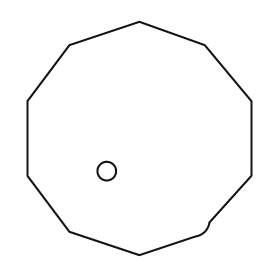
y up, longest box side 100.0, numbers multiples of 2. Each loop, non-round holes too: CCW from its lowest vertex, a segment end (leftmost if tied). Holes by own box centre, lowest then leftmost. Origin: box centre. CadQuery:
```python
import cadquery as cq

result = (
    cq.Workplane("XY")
    .moveTo(0.0, -50.0)
    .lineTo(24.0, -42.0)
    .threePointArc((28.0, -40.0), (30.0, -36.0))
    .lineTo(48.0, -16.0)
    .lineTo(48.0, 16.0)
    .lineTo(28.0, 40.0)
    .lineTo(0.0, 50.0)
    .lineTo(-30.0, 40.0)
    .lineTo(-48.0, 16.0)
    .lineTo(-48.0, -16.0)
    .lineTo(-30.0, -40.0)
    .close()
    .moveTo(-14.0, -14.0)
    .circle(4.0)
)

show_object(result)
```